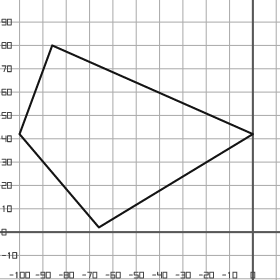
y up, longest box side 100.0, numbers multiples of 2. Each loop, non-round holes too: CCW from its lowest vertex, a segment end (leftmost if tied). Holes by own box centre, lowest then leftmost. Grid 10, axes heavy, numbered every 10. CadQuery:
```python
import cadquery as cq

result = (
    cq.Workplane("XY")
    .moveTo(-66.0, 2.0)
    .lineTo(0.0, 42.0)
    .lineTo(-86.0, 80.0)
    .lineTo(-100.0, 42.0)
    .close()
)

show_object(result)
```